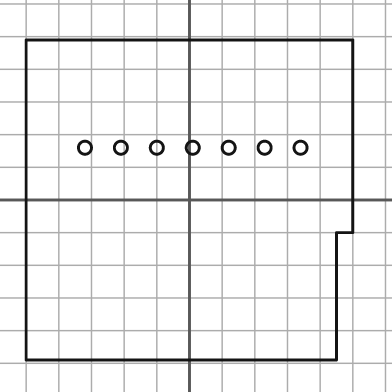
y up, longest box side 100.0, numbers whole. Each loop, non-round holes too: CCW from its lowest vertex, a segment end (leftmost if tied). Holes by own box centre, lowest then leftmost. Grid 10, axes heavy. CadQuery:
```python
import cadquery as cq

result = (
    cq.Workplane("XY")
    .moveTo(-50.0, -49.0)
    .lineTo(45.0, -49.0)
    .lineTo(45.0, -10.0)
    .lineTo(50.0, -10.0)
    .lineTo(50.0, 49.0)
    .lineTo(-50.0, 49.0)
    .close()
    .moveTo(-32.0, 16.0)
    .circle(2.0)
    .moveTo(-21.0, 16.0)
    .circle(2.0)
    .moveTo(-10.0, 16.0)
    .circle(2.0)
    .moveTo(1.0, 16.0)
    .circle(2.0)
    .moveTo(12.0, 16.0)
    .circle(2.0)
    .moveTo(23.0, 16.0)
    .circle(2.0)
    .moveTo(34.0, 16.0)
    .circle(2.0)
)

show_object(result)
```